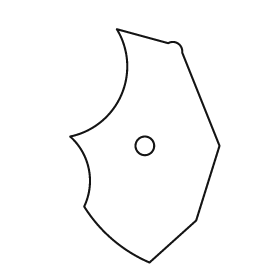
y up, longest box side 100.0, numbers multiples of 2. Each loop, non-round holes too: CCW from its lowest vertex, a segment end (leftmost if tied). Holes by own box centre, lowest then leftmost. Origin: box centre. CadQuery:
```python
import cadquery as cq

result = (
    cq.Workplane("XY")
    .moveTo(2.0, -50.0)
    .lineTo(22.0, -32.0)
    .lineTo(32.0, 0.0)
    .lineTo(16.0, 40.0)
    .threePointArc((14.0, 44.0), (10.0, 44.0))
    .lineTo(-12.0, 50.0)
    .threePointArc((-10.0, 22.0), (-32.0, 4.0))
    .threePointArc((-24.0, -10.0), (-26.0, -26.0))
    .threePointArc((-14.0, -40.0), (2.0, -50.0))
    .close()
    .moveTo(0.0, 0.0)
    .circle(4.0)
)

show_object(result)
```